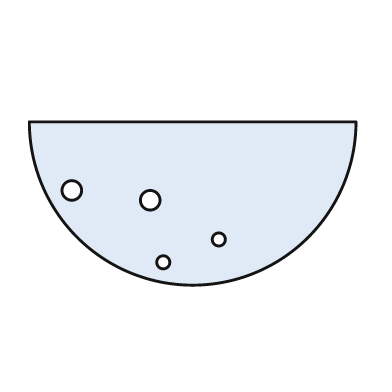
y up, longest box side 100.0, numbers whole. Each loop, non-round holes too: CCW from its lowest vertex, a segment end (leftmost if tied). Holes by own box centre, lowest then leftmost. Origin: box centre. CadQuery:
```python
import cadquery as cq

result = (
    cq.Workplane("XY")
    .moveTo(-50.0, 25.0)
    .threePointArc((0.0, -25.0), (50.0, 25.0))
    .close()
    .moveTo(-9.0, -18.0)
    .circle(2.0)
    .moveTo(8.0, -11.0)
    .circle(2.0)
    .moveTo(-13.0, 1.0)
    .circle(3.0)
    .moveTo(-37.0, 4.0)
    .circle(3.0)
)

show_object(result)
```